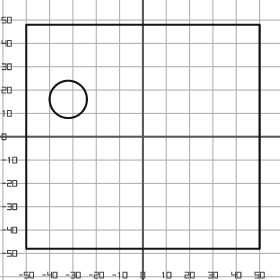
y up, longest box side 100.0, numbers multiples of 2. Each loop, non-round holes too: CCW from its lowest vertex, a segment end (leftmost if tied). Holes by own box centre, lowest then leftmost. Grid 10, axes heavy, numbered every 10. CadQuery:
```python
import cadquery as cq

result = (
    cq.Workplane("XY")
    .moveTo(-50.0, -48.0)
    .lineTo(50.0, -48.0)
    .lineTo(50.0, 48.0)
    .lineTo(-50.0, 48.0)
    .close()
    .moveTo(-32.0, 16.0)
    .circle(8.0)
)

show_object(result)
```